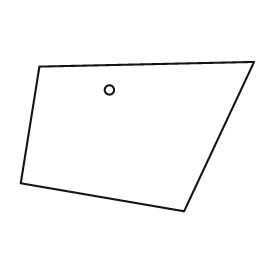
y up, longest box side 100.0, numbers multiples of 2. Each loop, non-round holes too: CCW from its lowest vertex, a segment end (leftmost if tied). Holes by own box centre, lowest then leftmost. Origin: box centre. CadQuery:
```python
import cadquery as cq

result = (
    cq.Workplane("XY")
    .moveTo(20.0, -32.0)
    .lineTo(50.0, 32.0)
    .lineTo(-42.0, 30.0)
    .lineTo(-50.0, -20.0)
    .close()
    .moveTo(-12.0, 20.0)
    .circle(2.0)
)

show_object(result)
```